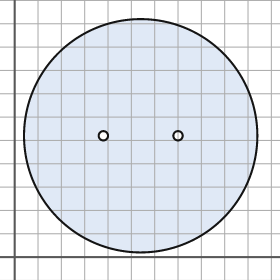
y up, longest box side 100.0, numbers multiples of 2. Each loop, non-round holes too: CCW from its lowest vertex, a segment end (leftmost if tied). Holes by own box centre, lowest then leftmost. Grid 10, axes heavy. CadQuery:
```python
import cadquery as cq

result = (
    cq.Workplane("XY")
    .moveTo(54.0, 52.0)
    .circle(50.0)
    .moveTo(38.0, 52.0)
    .circle(2.0)
    .moveTo(70.0, 52.0)
    .circle(2.0)
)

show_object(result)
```